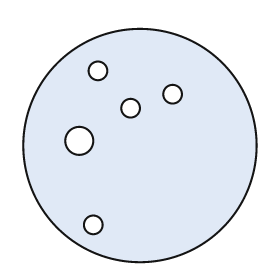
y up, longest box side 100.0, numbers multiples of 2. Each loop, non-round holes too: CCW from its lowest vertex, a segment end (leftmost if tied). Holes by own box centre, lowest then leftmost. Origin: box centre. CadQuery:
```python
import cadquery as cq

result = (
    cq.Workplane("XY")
    .moveTo(0.0, 0.0)
    .circle(50.0)
    .moveTo(-20.0, -34.0)
    .circle(4.0)
    .moveTo(-26.0, 2.0)
    .circle(6.0)
    .moveTo(-4.0, 16.0)
    .circle(4.0)
    .moveTo(14.0, 22.0)
    .circle(4.0)
    .moveTo(-18.0, 32.0)
    .circle(4.0)
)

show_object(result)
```